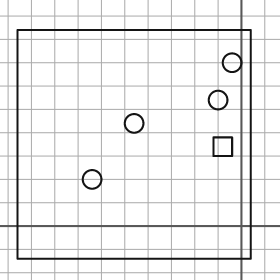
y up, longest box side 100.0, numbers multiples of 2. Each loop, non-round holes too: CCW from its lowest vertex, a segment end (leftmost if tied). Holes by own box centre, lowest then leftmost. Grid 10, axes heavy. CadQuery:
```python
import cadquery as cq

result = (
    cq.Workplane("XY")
    .moveTo(-96.0, -14.0)
    .lineTo(4.0, -14.0)
    .lineTo(4.0, 84.0)
    .lineTo(-96.0, 84.0)
    .close()
    .moveTo(-64.0, 20.0)
    .circle(4.0)
    .moveTo(-12.0, 30.0)
    .lineTo(-4.0, 30.0)
    .lineTo(-4.0, 38.0)
    .lineTo(-12.0, 38.0)
    .close()
    .moveTo(-46.0, 44.0)
    .circle(4.0)
    .moveTo(-10.0, 54.0)
    .circle(4.0)
    .moveTo(-4.0, 70.0)
    .circle(4.0)
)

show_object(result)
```